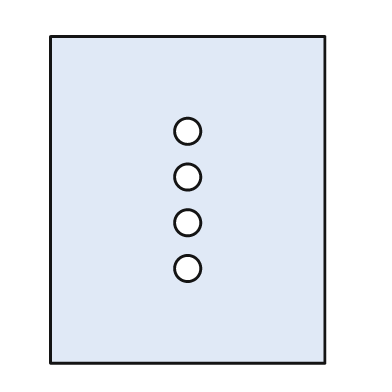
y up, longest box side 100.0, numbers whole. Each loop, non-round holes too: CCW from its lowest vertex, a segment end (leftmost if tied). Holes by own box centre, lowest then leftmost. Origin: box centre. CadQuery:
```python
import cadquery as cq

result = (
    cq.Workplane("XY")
    .moveTo(-42.0, -50.0)
    .lineTo(42.0, -50.0)
    .lineTo(42.0, 50.0)
    .lineTo(-42.0, 50.0)
    .close()
    .moveTo(0.0, -21.0)
    .circle(4.0)
    .moveTo(0.0, -7.0)
    .circle(4.0)
    .moveTo(0.0, 7.0)
    .circle(4.0)
    .moveTo(0.0, 21.0)
    .circle(4.0)
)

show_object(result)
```